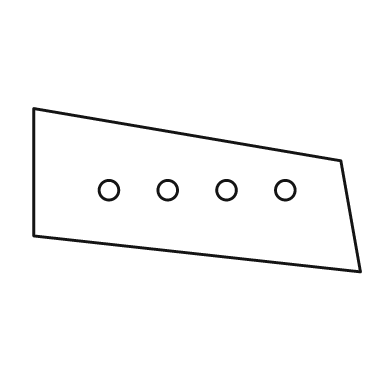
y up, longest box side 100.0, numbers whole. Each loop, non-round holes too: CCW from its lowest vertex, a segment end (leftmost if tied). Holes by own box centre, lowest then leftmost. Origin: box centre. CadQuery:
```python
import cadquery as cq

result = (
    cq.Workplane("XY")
    .moveTo(50.0, -25.0)
    .lineTo(44.0, 9.0)
    .lineTo(-50.0, 25.0)
    .lineTo(-50.0, -14.0)
    .close()
    .moveTo(-27.0, 0.0)
    .circle(3.0)
    .moveTo(-9.0, 0.0)
    .circle(3.0)
    .moveTo(9.0, 0.0)
    .circle(3.0)
    .moveTo(27.0, 0.0)
    .circle(3.0)
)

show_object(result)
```